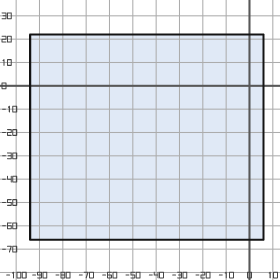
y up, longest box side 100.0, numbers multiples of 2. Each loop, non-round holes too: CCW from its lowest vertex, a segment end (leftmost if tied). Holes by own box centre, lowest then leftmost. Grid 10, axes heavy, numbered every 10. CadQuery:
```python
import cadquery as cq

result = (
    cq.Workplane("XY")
    .moveTo(-94.0, -66.0)
    .lineTo(6.0, -66.0)
    .lineTo(6.0, 22.0)
    .lineTo(-94.0, 22.0)
    .close()
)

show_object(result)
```